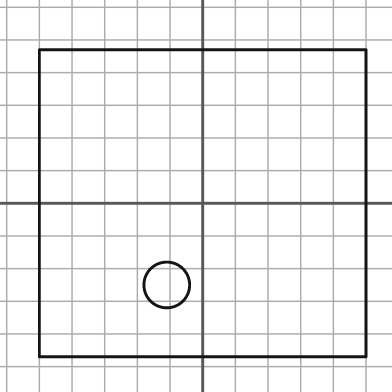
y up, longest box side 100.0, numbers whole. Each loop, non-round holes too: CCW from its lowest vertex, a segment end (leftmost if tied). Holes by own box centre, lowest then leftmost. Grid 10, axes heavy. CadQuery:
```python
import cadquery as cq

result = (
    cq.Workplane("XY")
    .moveTo(-50.0, -47.0)
    .lineTo(50.0, -47.0)
    .lineTo(50.0, 47.0)
    .lineTo(-50.0, 47.0)
    .close()
    .moveTo(-11.0, -25.0)
    .circle(7.0)
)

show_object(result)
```